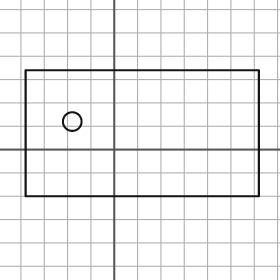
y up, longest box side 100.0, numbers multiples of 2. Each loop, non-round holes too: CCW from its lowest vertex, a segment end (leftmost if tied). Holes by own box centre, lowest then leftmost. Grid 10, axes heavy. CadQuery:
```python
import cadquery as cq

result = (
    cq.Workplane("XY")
    .moveTo(-38.0, -20.0)
    .lineTo(62.0, -20.0)
    .lineTo(62.0, 34.0)
    .lineTo(-38.0, 34.0)
    .close()
    .moveTo(-18.0, 12.0)
    .circle(4.0)
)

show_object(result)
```